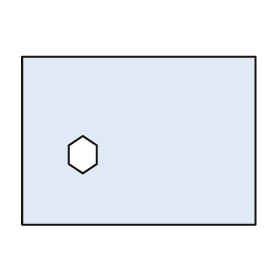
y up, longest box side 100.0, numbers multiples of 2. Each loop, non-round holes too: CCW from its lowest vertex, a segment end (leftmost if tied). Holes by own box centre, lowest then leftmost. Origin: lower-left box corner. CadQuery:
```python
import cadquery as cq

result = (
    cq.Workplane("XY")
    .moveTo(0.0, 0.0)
    .lineTo(100.0, 0.0)
    .lineTo(100.0, 72.0)
    .lineTo(0.0, 72.0)
    .close()
    .moveTo(26.0, 22.0)
    .lineTo(32.0, 26.0)
    .lineTo(32.0, 34.0)
    .lineTo(26.0, 38.0)
    .lineTo(20.0, 34.0)
    .lineTo(20.0, 26.0)
    .close()
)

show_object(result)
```